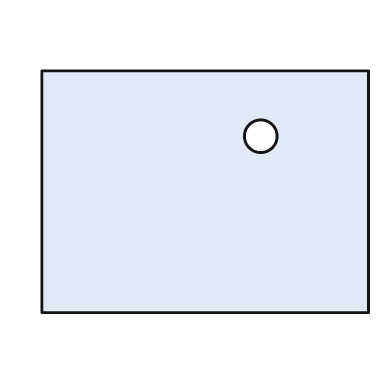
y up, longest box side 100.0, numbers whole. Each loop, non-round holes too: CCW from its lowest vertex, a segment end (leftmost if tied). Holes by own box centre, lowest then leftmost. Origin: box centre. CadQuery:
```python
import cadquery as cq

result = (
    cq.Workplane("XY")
    .moveTo(-50.0, -37.0)
    .lineTo(50.0, -37.0)
    .lineTo(50.0, 37.0)
    .lineTo(-50.0, 37.0)
    .close()
    .moveTo(17.0, 17.0)
    .circle(5.0)
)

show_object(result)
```